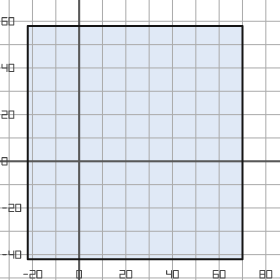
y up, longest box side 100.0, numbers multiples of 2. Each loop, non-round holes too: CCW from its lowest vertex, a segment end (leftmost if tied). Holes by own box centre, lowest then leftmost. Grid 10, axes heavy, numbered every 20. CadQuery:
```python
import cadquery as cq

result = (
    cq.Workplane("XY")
    .moveTo(-22.0, -42.0)
    .lineTo(70.0, -42.0)
    .lineTo(70.0, 58.0)
    .lineTo(-22.0, 58.0)
    .close()
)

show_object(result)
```